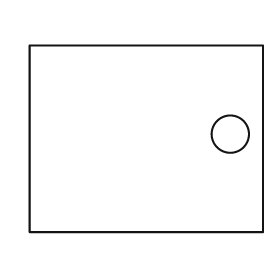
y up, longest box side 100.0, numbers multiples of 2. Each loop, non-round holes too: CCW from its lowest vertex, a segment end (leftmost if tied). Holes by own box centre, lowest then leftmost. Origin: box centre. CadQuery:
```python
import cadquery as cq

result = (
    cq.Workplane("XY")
    .moveTo(-50.0, -40.0)
    .lineTo(50.0, -40.0)
    .lineTo(50.0, 40.0)
    .lineTo(-50.0, 40.0)
    .close()
    .moveTo(36.0, 2.0)
    .circle(8.0)
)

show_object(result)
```